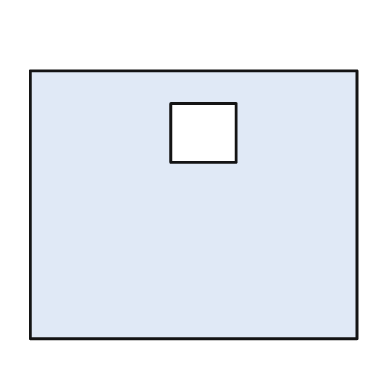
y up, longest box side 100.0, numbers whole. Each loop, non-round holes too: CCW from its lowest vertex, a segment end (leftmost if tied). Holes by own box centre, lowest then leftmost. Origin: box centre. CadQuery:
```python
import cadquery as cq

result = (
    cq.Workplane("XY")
    .moveTo(-50.0, -41.0)
    .lineTo(50.0, -41.0)
    .lineTo(50.0, 41.0)
    .lineTo(-50.0, 41.0)
    .close()
    .moveTo(-7.0, 13.0)
    .lineTo(13.0, 13.0)
    .lineTo(13.0, 31.0)
    .lineTo(-7.0, 31.0)
    .close()
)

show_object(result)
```